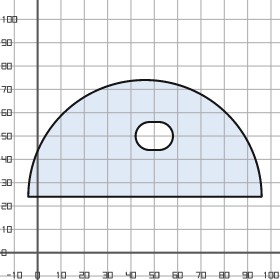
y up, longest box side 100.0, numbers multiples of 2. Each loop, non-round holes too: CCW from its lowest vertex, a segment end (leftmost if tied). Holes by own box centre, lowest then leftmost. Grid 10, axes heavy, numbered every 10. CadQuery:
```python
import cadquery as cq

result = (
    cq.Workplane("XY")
    .moveTo(-4.0, 24.0)
    .lineTo(96.0, 24.0)
    .threePointArc((46.0, 74.0), (-4.0, 24.0))
    .close()
    .moveTo(48.0, 44.0)
    .lineTo(52.0, 44.0)
    .threePointArc((58.0, 50.0), (52.0, 56.0))
    .lineTo(48.0, 56.0)
    .threePointArc((42.0, 50.0), (48.0, 44.0))
    .close()
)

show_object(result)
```